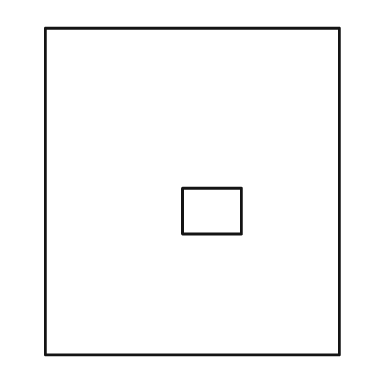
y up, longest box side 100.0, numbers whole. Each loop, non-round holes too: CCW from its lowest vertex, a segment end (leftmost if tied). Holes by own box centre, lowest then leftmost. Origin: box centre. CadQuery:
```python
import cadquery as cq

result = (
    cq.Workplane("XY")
    .moveTo(-45.0, -50.0)
    .lineTo(45.0, -50.0)
    .lineTo(45.0, 50.0)
    .lineTo(-45.0, 50.0)
    .close()
    .moveTo(-3.0, -13.0)
    .lineTo(15.0, -13.0)
    .lineTo(15.0, 1.0)
    .lineTo(-3.0, 1.0)
    .close()
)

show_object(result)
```